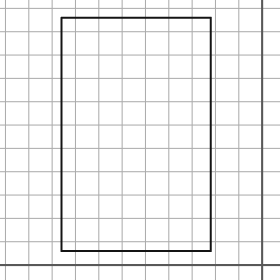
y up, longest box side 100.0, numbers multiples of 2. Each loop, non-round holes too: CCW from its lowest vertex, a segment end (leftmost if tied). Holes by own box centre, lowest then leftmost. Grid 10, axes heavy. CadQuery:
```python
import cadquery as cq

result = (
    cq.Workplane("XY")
    .moveTo(-86.0, 6.0)
    .lineTo(-22.0, 6.0)
    .lineTo(-22.0, 106.0)
    .lineTo(-86.0, 106.0)
    .close()
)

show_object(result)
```